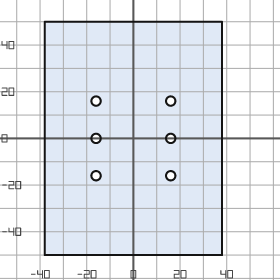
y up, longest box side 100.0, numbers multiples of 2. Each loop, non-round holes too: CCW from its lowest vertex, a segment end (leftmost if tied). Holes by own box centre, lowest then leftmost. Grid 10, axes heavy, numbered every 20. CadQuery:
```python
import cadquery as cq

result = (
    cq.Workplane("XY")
    .moveTo(-38.0, -50.0)
    .lineTo(38.0, -50.0)
    .lineTo(38.0, 50.0)
    .lineTo(-38.0, 50.0)
    .close()
    .moveTo(-16.0, -16.0)
    .circle(2.0)
    .moveTo(16.0, -16.0)
    .circle(2.0)
    .moveTo(-16.0, 0.0)
    .circle(2.0)
    .moveTo(16.0, 0.0)
    .circle(2.0)
    .moveTo(-16.0, 16.0)
    .circle(2.0)
    .moveTo(16.0, 16.0)
    .circle(2.0)
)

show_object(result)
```